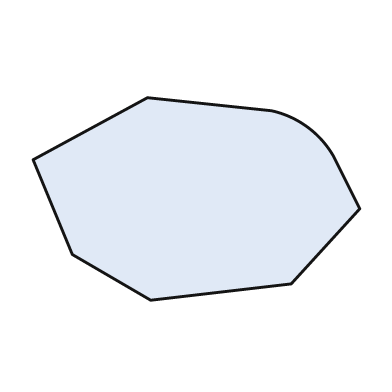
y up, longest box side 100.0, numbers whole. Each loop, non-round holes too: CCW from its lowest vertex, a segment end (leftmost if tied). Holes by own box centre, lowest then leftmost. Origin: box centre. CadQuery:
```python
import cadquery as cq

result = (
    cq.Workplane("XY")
    .moveTo(-14.0, -31.0)
    .lineTo(29.0, -26.0)
    .lineTo(50.0, -3.0)
    .lineTo(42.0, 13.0)
    .threePointArc((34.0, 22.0), (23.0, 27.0))
    .lineTo(-15.0, 31.0)
    .lineTo(-50.0, 12.0)
    .lineTo(-38.0, -17.0)
    .close()
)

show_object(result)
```